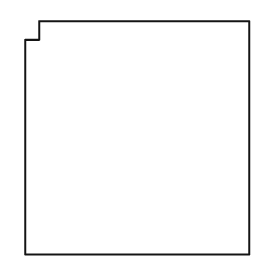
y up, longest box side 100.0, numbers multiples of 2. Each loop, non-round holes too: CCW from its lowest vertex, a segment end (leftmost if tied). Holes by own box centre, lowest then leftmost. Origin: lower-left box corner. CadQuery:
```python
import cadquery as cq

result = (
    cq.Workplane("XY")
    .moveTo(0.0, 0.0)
    .lineTo(96.0, 0.0)
    .lineTo(96.0, 100.0)
    .lineTo(6.0, 100.0)
    .lineTo(6.0, 92.0)
    .lineTo(0.0, 92.0)
    .close()
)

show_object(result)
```